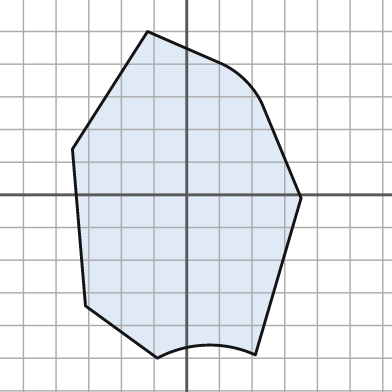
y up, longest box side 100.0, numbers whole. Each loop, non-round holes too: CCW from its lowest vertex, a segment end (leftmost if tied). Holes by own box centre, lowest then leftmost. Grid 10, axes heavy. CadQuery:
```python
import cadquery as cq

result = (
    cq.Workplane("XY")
    .moveTo(-9.0, -50.0)
    .threePointArc((6.0, -46.0), (21.0, -49.0))
    .lineTo(35.0, -1.0)
    .lineTo(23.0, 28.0)
    .threePointArc((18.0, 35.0), (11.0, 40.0))
    .lineTo(-12.0, 50.0)
    .lineTo(-35.0, 14.0)
    .lineTo(-31.0, -34.0)
    .close()
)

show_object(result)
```